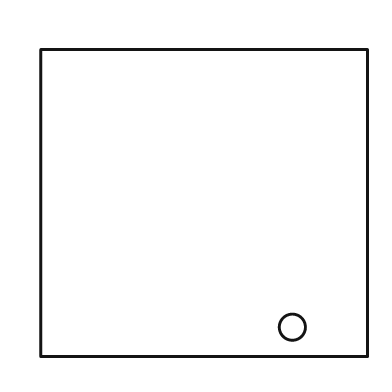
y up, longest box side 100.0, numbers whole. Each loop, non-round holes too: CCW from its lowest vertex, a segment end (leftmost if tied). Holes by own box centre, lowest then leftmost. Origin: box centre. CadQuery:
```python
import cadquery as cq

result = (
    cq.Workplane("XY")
    .moveTo(-50.0, -47.0)
    .lineTo(50.0, -47.0)
    .lineTo(50.0, 47.0)
    .lineTo(-50.0, 47.0)
    .close()
    .moveTo(27.0, -38.0)
    .circle(4.0)
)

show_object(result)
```